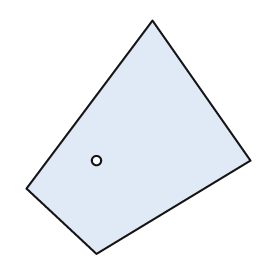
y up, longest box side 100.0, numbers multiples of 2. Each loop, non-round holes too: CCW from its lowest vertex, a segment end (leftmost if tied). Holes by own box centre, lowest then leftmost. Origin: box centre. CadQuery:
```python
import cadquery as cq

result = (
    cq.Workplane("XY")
    .moveTo(-18.0, -50.0)
    .lineTo(48.0, -10.0)
    .lineTo(6.0, 50.0)
    .lineTo(-48.0, -22.0)
    .close()
    .moveTo(-18.0, -10.0)
    .circle(2.0)
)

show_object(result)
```